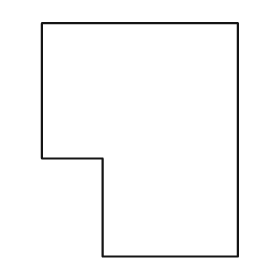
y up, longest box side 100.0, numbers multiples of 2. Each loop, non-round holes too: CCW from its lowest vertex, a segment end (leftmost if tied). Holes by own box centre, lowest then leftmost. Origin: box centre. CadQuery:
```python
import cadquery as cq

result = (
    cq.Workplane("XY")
    .moveTo(-16.0, -50.0)
    .lineTo(42.0, -50.0)
    .lineTo(42.0, 50.0)
    .lineTo(-42.0, 50.0)
    .lineTo(-42.0, -8.0)
    .lineTo(-16.0, -8.0)
    .close()
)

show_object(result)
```